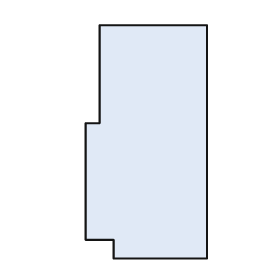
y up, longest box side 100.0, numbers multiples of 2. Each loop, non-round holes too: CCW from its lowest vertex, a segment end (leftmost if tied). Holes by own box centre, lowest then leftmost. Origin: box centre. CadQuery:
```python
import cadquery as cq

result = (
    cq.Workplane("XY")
    .moveTo(-14.0, -50.0)
    .lineTo(26.0, -50.0)
    .lineTo(26.0, 50.0)
    .lineTo(-20.0, 50.0)
    .lineTo(-20.0, 8.0)
    .lineTo(-26.0, 8.0)
    .lineTo(-26.0, -42.0)
    .lineTo(-14.0, -42.0)
    .close()
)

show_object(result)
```